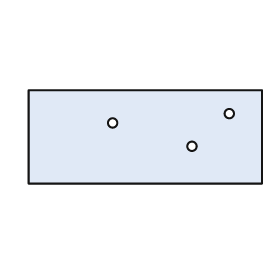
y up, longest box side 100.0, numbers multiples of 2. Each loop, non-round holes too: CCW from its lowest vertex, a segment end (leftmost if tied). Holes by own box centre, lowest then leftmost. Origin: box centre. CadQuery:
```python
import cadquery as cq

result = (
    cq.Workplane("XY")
    .moveTo(-50.0, -20.0)
    .lineTo(50.0, -20.0)
    .lineTo(50.0, 20.0)
    .lineTo(-50.0, 20.0)
    .close()
    .moveTo(20.0, -4.0)
    .circle(2.0)
    .moveTo(-14.0, 6.0)
    .circle(2.0)
    .moveTo(36.0, 10.0)
    .circle(2.0)
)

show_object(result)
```